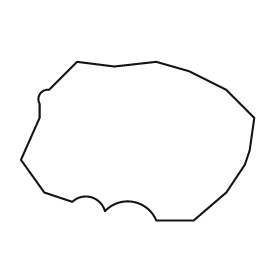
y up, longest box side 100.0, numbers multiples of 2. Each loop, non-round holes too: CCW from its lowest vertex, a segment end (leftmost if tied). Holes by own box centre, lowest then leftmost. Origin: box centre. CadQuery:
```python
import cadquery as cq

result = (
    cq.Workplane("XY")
    .moveTo(8.0, -34.0)
    .lineTo(24.0, -34.0)
    .lineTo(38.0, -22.0)
    .lineTo(46.0, -10.0)
    .lineTo(48.0, -4.0)
    .lineTo(50.0, 10.0)
    .lineTo(38.0, 22.0)
    .lineTo(22.0, 30.0)
    .lineTo(8.0, 34.0)
    .lineTo(-10.0, 32.0)
    .lineTo(-26.0, 34.0)
    .lineTo(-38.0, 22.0)
    .threePointArc((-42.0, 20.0), (-42.0, 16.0))
    .lineTo(-42.0, 10.0)
    .lineTo(-50.0, -8.0)
    .lineTo(-40.0, -22.0)
    .lineTo(-28.0, -26.0)
    .threePointArc((-20.0, -24.0), (-14.0, -30.0))
    .threePointArc((-2.0, -26.0), (8.0, -34.0))
    .close()
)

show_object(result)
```